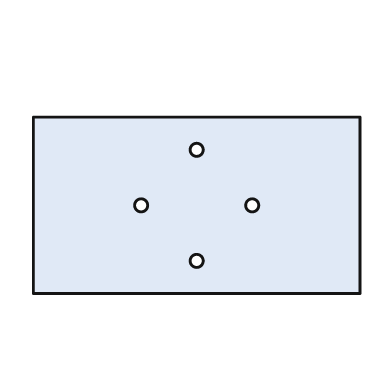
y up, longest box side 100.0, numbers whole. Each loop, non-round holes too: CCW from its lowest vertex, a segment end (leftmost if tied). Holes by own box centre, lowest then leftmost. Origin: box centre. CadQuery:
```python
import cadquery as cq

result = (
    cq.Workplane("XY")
    .moveTo(-50.0, -27.0)
    .lineTo(50.0, -27.0)
    .lineTo(50.0, 27.0)
    .lineTo(-50.0, 27.0)
    .close()
    .moveTo(0.0, -17.0)
    .circle(2.0)
    .moveTo(-17.0, 0.0)
    .circle(2.0)
    .moveTo(17.0, 0.0)
    .circle(2.0)
    .moveTo(0.0, 17.0)
    .circle(2.0)
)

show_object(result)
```